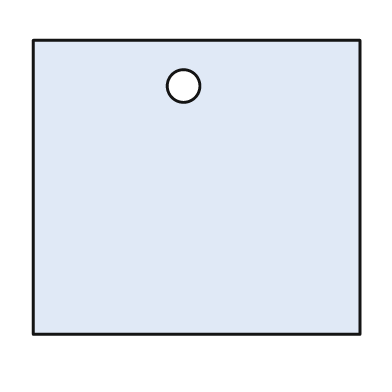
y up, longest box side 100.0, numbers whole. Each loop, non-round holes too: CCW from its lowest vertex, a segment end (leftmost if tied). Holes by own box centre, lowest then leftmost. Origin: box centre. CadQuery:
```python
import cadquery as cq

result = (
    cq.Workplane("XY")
    .moveTo(-50.0, -45.0)
    .lineTo(50.0, -45.0)
    .lineTo(50.0, 45.0)
    .lineTo(-50.0, 45.0)
    .close()
    .moveTo(-4.0, 31.0)
    .circle(5.0)
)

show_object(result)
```